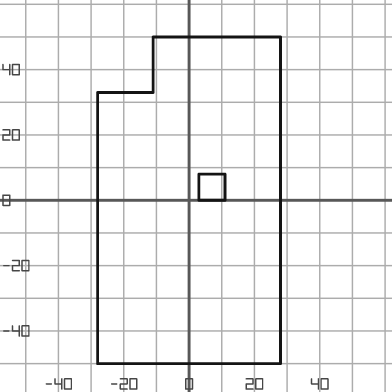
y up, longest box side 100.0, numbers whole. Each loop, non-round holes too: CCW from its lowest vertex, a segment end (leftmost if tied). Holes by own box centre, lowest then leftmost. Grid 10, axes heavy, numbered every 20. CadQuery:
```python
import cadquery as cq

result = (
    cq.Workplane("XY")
    .moveTo(-28.0, -50.0)
    .lineTo(28.0, -50.0)
    .lineTo(28.0, 50.0)
    .lineTo(-11.0, 50.0)
    .lineTo(-11.0, 33.0)
    .lineTo(-28.0, 33.0)
    .close()
    .moveTo(3.0, 0.0)
    .lineTo(11.0, 0.0)
    .lineTo(11.0, 8.0)
    .lineTo(3.0, 8.0)
    .close()
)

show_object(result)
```